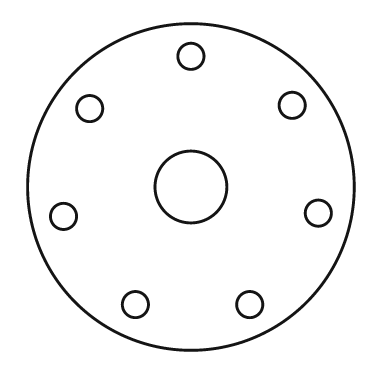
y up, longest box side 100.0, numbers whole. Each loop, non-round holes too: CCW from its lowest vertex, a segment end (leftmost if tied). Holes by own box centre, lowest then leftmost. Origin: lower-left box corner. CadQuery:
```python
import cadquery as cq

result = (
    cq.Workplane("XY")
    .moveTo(50.0, 50.0)
    .circle(50.0)
    .moveTo(33.0, 14.0)
    .circle(4.0)
    .moveTo(68.0, 14.0)
    .circle(4.0)
    .moveTo(11.0, 41.0)
    .circle(4.0)
    .moveTo(89.0, 42.0)
    .circle(4.0)
    .moveTo(50.0, 50.0)
    .circle(11.0)
    .moveTo(19.0, 74.0)
    .circle(4.0)
    .moveTo(81.0, 75.0)
    .circle(4.0)
    .moveTo(50.0, 90.0)
    .circle(4.0)
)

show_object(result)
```